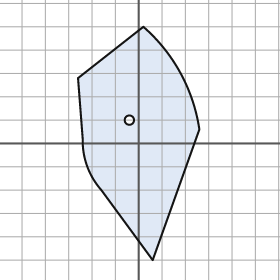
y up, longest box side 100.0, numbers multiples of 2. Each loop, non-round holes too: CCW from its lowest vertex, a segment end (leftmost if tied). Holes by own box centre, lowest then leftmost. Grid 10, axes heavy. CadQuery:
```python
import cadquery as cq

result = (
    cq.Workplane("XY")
    .moveTo(6.0, -50.0)
    .lineTo(26.0, 6.0)
    .threePointArc((18.0, 30.0), (2.0, 50.0))
    .lineTo(-26.0, 28.0)
    .lineTo(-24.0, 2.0)
    .threePointArc((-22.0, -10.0), (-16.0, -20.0))
    .close()
    .moveTo(-4.0, 10.0)
    .circle(2.0)
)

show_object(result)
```